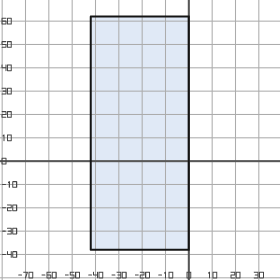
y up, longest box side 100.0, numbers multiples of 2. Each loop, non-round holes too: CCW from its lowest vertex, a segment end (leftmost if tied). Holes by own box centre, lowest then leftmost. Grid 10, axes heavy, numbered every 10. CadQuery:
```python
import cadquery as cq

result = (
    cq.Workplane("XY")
    .moveTo(-42.0, -38.0)
    .lineTo(0.0, -38.0)
    .lineTo(0.0, 62.0)
    .lineTo(-42.0, 62.0)
    .close()
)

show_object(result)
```